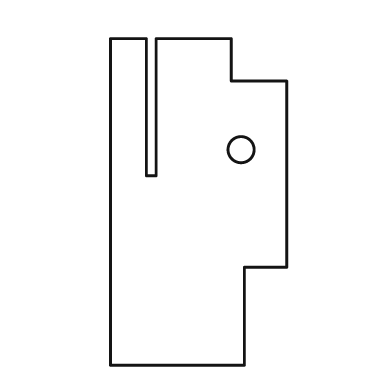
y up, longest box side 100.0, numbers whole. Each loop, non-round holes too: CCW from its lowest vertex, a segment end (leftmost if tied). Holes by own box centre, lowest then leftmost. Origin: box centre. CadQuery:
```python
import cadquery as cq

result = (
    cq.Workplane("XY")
    .moveTo(-27.0, -50.0)
    .lineTo(14.0, -50.0)
    .lineTo(14.0, -20.0)
    .lineTo(27.0, -20.0)
    .lineTo(27.0, 37.0)
    .lineTo(10.0, 37.0)
    .lineTo(10.0, 50.0)
    .lineTo(-13.0, 50.0)
    .lineTo(-13.0, 8.0)
    .lineTo(-16.0, 8.0)
    .lineTo(-16.0, 50.0)
    .lineTo(-27.0, 50.0)
    .close()
    .moveTo(13.0, 16.0)
    .circle(4.0)
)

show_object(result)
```